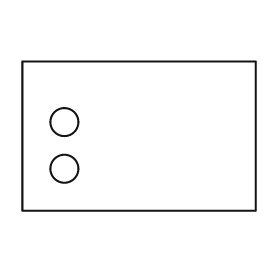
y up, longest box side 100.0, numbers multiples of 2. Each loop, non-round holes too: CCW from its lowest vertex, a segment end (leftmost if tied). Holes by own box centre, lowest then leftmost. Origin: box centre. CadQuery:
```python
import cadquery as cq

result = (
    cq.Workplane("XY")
    .moveTo(-50.0, -32.0)
    .lineTo(50.0, -32.0)
    .lineTo(50.0, 32.0)
    .lineTo(-50.0, 32.0)
    .close()
    .moveTo(-32.0, -14.0)
    .circle(6.0)
    .moveTo(-32.0, 6.0)
    .circle(6.0)
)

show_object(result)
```